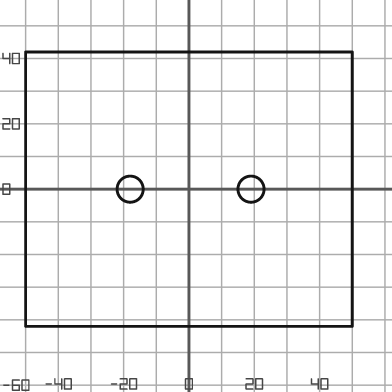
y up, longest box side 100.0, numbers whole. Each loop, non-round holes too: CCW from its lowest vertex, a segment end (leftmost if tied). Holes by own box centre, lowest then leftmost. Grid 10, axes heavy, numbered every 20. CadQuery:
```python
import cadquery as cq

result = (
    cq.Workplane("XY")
    .moveTo(-50.0, -42.0)
    .lineTo(50.0, -42.0)
    .lineTo(50.0, 42.0)
    .lineTo(-50.0, 42.0)
    .close()
    .moveTo(-18.0, 0.0)
    .circle(4.0)
    .moveTo(19.0, 0.0)
    .circle(4.0)
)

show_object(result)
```